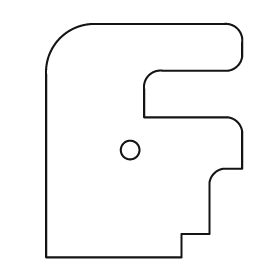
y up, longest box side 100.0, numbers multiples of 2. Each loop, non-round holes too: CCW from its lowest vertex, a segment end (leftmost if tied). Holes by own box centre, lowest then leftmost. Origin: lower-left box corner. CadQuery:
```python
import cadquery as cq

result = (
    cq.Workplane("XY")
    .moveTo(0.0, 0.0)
    .lineTo(58.0, 0.0)
    .lineTo(58.0, 10.0)
    .lineTo(70.0, 10.0)
    .lineTo(70.0, 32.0)
    .threePointArc((72.0, 36.0), (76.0, 38.0))
    .lineTo(84.0, 38.0)
    .lineTo(84.0, 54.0)
    .threePointArc((82.0, 58.0), (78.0, 60.0))
    .lineTo(42.0, 60.0)
    .lineTo(42.0, 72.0)
    .threePointArc((44.0, 78.0), (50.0, 80.0))
    .lineTo(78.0, 80.0)
    .threePointArc((82.0, 82.0), (84.0, 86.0))
    .lineTo(84.0, 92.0)
    .threePointArc((82.0, 98.0), (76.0, 100.0))
    .lineTo(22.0, 100.0)
    .threePointArc((6.0, 94.0), (0.0, 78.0))
    .close()
    .moveTo(36.0, 46.0)
    .circle(4.0)
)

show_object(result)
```